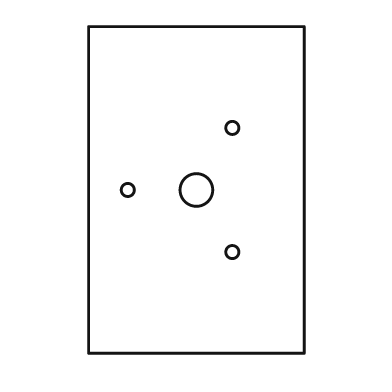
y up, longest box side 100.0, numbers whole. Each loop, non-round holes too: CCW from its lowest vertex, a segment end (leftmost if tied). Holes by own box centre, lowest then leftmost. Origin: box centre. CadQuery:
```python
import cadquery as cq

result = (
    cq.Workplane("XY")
    .moveTo(-33.0, -50.0)
    .lineTo(33.0, -50.0)
    .lineTo(33.0, 50.0)
    .lineTo(-33.0, 50.0)
    .close()
    .moveTo(11.0, -19.0)
    .circle(2.0)
    .moveTo(-21.0, 0.0)
    .circle(2.0)
    .moveTo(0.0, 0.0)
    .circle(5.0)
    .moveTo(11.0, 19.0)
    .circle(2.0)
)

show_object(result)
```